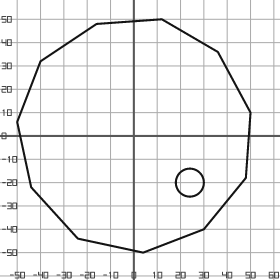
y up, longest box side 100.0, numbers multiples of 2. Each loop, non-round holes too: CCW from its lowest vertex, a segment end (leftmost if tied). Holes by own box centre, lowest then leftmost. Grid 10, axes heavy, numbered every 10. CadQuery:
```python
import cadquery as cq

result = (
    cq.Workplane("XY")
    .moveTo(4.0, -50.0)
    .lineTo(30.0, -40.0)
    .lineTo(48.0, -18.0)
    .lineTo(50.0, 10.0)
    .lineTo(36.0, 36.0)
    .lineTo(12.0, 50.0)
    .lineTo(-16.0, 48.0)
    .lineTo(-40.0, 32.0)
    .lineTo(-50.0, 6.0)
    .lineTo(-44.0, -22.0)
    .lineTo(-24.0, -44.0)
    .close()
    .moveTo(24.0, -20.0)
    .circle(6.0)
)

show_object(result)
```